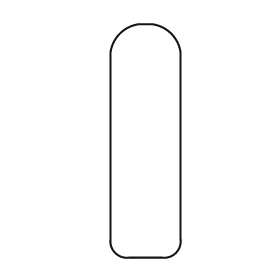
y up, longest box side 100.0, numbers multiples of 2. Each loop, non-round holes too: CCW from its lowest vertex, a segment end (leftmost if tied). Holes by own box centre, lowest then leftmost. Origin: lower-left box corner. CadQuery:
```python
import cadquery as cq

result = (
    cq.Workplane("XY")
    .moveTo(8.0, 0.0)
    .lineTo(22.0, 0.0)
    .threePointArc((28.0, 2.0), (30.0, 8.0))
    .lineTo(30.0, 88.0)
    .threePointArc((26.0, 96.0), (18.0, 100.0))
    .lineTo(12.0, 100.0)
    .threePointArc((4.0, 96.0), (0.0, 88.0))
    .lineTo(0.0, 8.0)
    .threePointArc((2.0, 2.0), (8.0, 0.0))
    .close()
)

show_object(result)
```